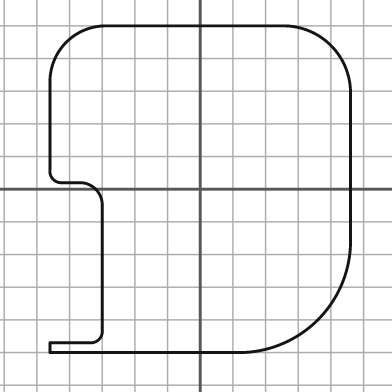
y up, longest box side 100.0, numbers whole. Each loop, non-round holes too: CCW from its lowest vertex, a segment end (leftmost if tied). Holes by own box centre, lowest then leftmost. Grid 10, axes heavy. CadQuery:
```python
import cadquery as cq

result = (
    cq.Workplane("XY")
    .moveTo(-46.0, -50.0)
    .lineTo(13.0, -50.0)
    .threePointArc((36.0, -40.0), (46.0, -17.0))
    .lineTo(46.0, 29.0)
    .threePointArc((40.0, 44.0), (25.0, 50.0))
    .lineTo(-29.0, 50.0)
    .threePointArc((-41.0, 45.0), (-46.0, 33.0))
    .lineTo(-46.0, 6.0)
    .threePointArc((-45.0, 3.0), (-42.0, 2.0))
    .lineTo(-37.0, 2.0)
    .threePointArc((-32.0, 0.0), (-30.0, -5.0))
    .lineTo(-30.0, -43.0)
    .threePointArc((-31.0, -46.0), (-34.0, -47.0))
    .lineTo(-46.0, -47.0)
    .close()
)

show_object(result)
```